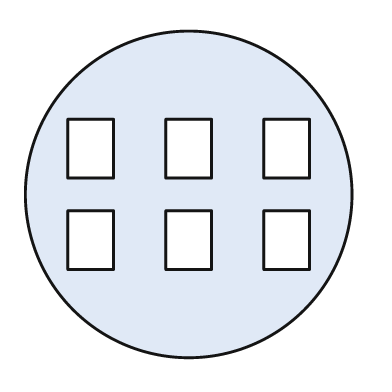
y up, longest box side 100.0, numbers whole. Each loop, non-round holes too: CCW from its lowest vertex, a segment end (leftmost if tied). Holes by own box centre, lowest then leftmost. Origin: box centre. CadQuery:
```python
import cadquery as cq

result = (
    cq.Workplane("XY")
    .moveTo(0.0, 0.0)
    .circle(50.0)
    .moveTo(-37.0, -23.0)
    .lineTo(-23.0, -23.0)
    .lineTo(-23.0, -5.0)
    .lineTo(-37.0, -5.0)
    .close()
    .moveTo(-7.0, -23.0)
    .lineTo(7.0, -23.0)
    .lineTo(7.0, -5.0)
    .lineTo(-7.0, -5.0)
    .close()
    .moveTo(23.0, -23.0)
    .lineTo(37.0, -23.0)
    .lineTo(37.0, -5.0)
    .lineTo(23.0, -5.0)
    .close()
    .moveTo(-37.0, 5.0)
    .lineTo(-23.0, 5.0)
    .lineTo(-23.0, 23.0)
    .lineTo(-37.0, 23.0)
    .close()
    .moveTo(-7.0, 5.0)
    .lineTo(7.0, 5.0)
    .lineTo(7.0, 23.0)
    .lineTo(-7.0, 23.0)
    .close()
    .moveTo(23.0, 5.0)
    .lineTo(37.0, 5.0)
    .lineTo(37.0, 23.0)
    .lineTo(23.0, 23.0)
    .close()
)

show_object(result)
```